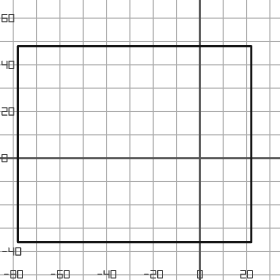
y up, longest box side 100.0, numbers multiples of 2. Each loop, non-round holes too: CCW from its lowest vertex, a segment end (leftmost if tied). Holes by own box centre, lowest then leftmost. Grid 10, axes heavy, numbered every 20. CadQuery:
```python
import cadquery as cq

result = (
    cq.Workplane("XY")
    .moveTo(-78.0, -36.0)
    .lineTo(22.0, -36.0)
    .lineTo(22.0, 48.0)
    .lineTo(-78.0, 48.0)
    .close()
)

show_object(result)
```